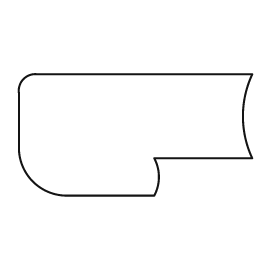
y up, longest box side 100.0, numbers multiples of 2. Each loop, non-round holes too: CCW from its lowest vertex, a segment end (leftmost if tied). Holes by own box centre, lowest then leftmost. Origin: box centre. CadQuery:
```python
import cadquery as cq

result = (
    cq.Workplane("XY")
    .moveTo(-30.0, -26.0)
    .lineTo(8.0, -26.0)
    .threePointArc((10.0, -18.0), (8.0, -10.0))
    .lineTo(50.0, -10.0)
    .threePointArc((46.0, 8.0), (50.0, 26.0))
    .lineTo(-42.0, 26.0)
    .threePointArc((-48.0, 24.0), (-50.0, 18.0))
    .lineTo(-50.0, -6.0)
    .threePointArc((-44.0, -20.0), (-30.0, -26.0))
    .close()
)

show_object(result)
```